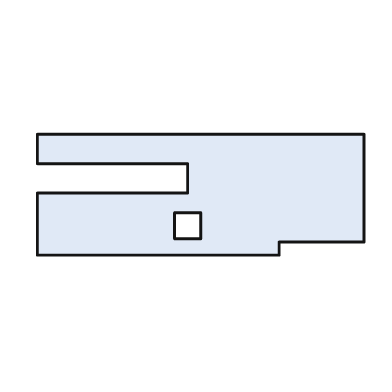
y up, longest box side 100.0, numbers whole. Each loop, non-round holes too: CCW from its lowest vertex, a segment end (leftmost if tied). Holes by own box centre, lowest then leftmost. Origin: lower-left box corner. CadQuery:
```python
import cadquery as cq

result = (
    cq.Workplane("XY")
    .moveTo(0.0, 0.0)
    .lineTo(74.0, 0.0)
    .lineTo(74.0, 4.0)
    .lineTo(100.0, 4.0)
    .lineTo(100.0, 37.0)
    .lineTo(0.0, 37.0)
    .lineTo(0.0, 28.0)
    .lineTo(46.0, 28.0)
    .lineTo(46.0, 19.0)
    .lineTo(0.0, 19.0)
    .close()
    .moveTo(42.0, 5.0)
    .lineTo(50.0, 5.0)
    .lineTo(50.0, 13.0)
    .lineTo(42.0, 13.0)
    .close()
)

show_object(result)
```